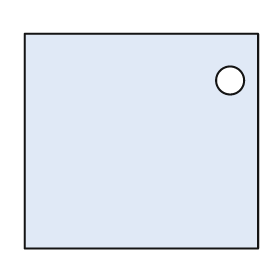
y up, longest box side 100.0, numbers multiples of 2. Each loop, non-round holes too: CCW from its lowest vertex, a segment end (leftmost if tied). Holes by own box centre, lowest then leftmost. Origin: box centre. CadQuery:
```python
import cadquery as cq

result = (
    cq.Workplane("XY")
    .moveTo(-50.0, -46.0)
    .lineTo(50.0, -46.0)
    .lineTo(50.0, 46.0)
    .lineTo(-50.0, 46.0)
    .close()
    .moveTo(38.0, 26.0)
    .circle(6.0)
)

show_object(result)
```